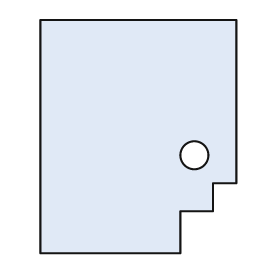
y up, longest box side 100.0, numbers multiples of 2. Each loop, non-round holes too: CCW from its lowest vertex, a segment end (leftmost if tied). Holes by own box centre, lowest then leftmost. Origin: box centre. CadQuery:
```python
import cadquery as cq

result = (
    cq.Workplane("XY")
    .moveTo(-42.0, -50.0)
    .lineTo(18.0, -50.0)
    .lineTo(18.0, -32.0)
    .lineTo(32.0, -32.0)
    .lineTo(32.0, -20.0)
    .lineTo(42.0, -20.0)
    .lineTo(42.0, 50.0)
    .lineTo(-42.0, 50.0)
    .close()
    .moveTo(24.0, -8.0)
    .circle(6.0)
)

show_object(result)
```